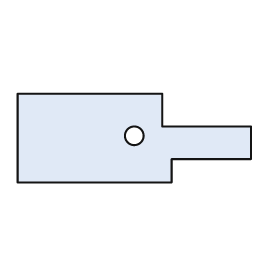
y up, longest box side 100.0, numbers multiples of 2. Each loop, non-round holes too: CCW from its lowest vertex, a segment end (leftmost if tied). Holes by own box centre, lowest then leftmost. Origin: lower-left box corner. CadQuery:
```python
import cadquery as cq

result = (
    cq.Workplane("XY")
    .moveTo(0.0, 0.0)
    .lineTo(66.0, 0.0)
    .lineTo(66.0, 10.0)
    .lineTo(100.0, 10.0)
    .lineTo(100.0, 24.0)
    .lineTo(62.0, 24.0)
    .lineTo(62.0, 38.0)
    .lineTo(0.0, 38.0)
    .close()
    .moveTo(50.0, 20.0)
    .circle(4.0)
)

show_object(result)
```